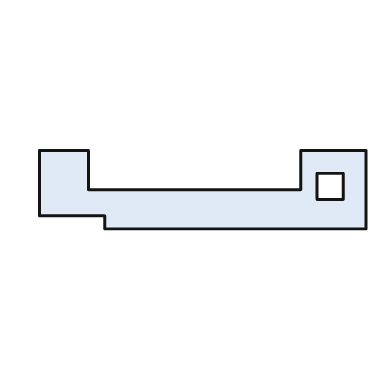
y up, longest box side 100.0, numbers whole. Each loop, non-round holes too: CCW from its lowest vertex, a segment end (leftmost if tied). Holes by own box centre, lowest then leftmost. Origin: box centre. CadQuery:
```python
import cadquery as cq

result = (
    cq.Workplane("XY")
    .moveTo(-30.0, -12.0)
    .lineTo(50.0, -12.0)
    .lineTo(50.0, 12.0)
    .lineTo(30.0, 12.0)
    .lineTo(30.0, 0.0)
    .lineTo(-35.0, 0.0)
    .lineTo(-35.0, 12.0)
    .lineTo(-50.0, 12.0)
    .lineTo(-50.0, -8.0)
    .lineTo(-30.0, -8.0)
    .close()
    .moveTo(35.0, -3.0)
    .lineTo(43.0, -3.0)
    .lineTo(43.0, 5.0)
    .lineTo(35.0, 5.0)
    .close()
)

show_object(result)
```